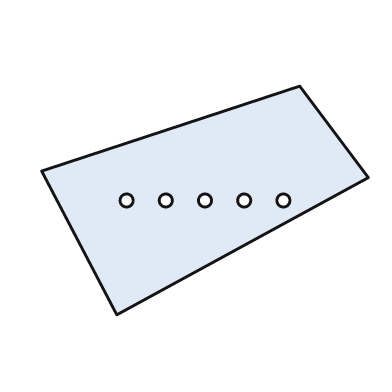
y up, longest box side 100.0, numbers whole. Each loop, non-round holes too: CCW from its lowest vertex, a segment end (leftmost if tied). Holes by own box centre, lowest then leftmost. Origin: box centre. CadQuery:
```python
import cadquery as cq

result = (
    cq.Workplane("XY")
    .moveTo(-27.0, -35.0)
    .lineTo(50.0, 7.0)
    .lineTo(29.0, 35.0)
    .lineTo(-50.0, 9.0)
    .close()
    .moveTo(-24.0, 0.0)
    .circle(2.0)
    .moveTo(-12.0, 0.0)
    .circle(2.0)
    .moveTo(0.0, 0.0)
    .circle(2.0)
    .moveTo(12.0, 0.0)
    .circle(2.0)
    .moveTo(24.0, 0.0)
    .circle(2.0)
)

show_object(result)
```